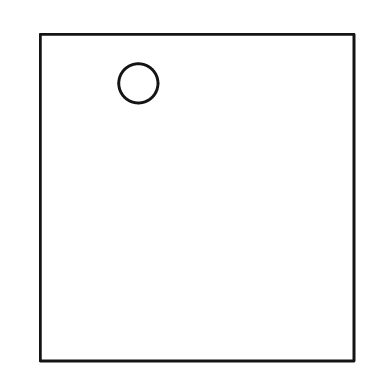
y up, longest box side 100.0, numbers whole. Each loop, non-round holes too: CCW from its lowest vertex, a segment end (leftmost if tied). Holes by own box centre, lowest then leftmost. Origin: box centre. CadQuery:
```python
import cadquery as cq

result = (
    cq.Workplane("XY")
    .moveTo(-48.0, -50.0)
    .lineTo(48.0, -50.0)
    .lineTo(48.0, 50.0)
    .lineTo(-48.0, 50.0)
    .close()
    .moveTo(-18.0, 35.0)
    .circle(6.0)
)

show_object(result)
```